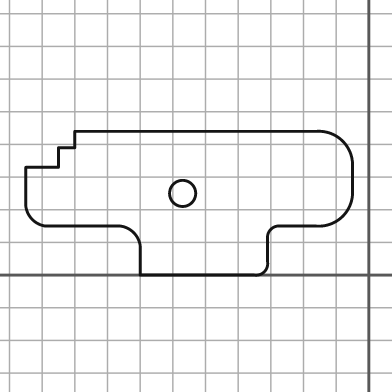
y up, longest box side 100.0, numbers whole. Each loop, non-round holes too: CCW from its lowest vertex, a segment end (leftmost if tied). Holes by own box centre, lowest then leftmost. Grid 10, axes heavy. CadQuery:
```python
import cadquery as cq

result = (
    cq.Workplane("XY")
    .moveTo(-70.0, 0.0)
    .lineTo(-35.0, 0.0)
    .threePointArc((-32.0, 1.0), (-31.0, 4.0))
    .lineTo(-31.0, 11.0)
    .threePointArc((-30.0, 14.0), (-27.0, 15.0))
    .lineTo(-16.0, 15.0)
    .threePointArc((-8.0, 18.0), (-5.0, 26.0))
    .lineTo(-5.0, 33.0)
    .threePointArc((-8.0, 41.0), (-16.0, 44.0))
    .lineTo(-90.0, 44.0)
    .lineTo(-90.0, 39.0)
    .lineTo(-95.0, 39.0)
    .lineTo(-95.0, 33.0)
    .lineTo(-105.0, 33.0)
    .lineTo(-105.0, 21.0)
    .threePointArc((-103.0, 17.0), (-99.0, 15.0))
    .lineTo(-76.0, 15.0)
    .threePointArc((-72.0, 13.0), (-70.0, 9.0))
    .close()
    .moveTo(-57.0, 25.0)
    .circle(4.0)
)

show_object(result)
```